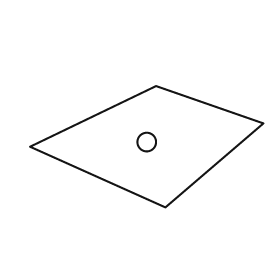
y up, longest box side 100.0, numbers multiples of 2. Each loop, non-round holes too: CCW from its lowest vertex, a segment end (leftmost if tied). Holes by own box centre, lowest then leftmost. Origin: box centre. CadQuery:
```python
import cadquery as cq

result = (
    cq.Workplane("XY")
    .moveTo(8.0, -26.0)
    .lineTo(50.0, 10.0)
    .lineTo(4.0, 26.0)
    .lineTo(-50.0, 0.0)
    .close()
    .moveTo(0.0, 2.0)
    .circle(4.0)
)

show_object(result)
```